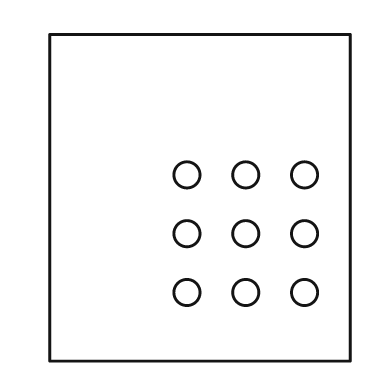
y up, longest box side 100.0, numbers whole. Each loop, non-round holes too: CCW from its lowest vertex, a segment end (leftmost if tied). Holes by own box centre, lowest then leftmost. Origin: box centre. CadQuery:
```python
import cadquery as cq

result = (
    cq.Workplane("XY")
    .moveTo(-46.0, -50.0)
    .lineTo(46.0, -50.0)
    .lineTo(46.0, 50.0)
    .lineTo(-46.0, 50.0)
    .close()
    .moveTo(-4.0, -29.0)
    .circle(4.0)
    .moveTo(14.0, -29.0)
    .circle(4.0)
    .moveTo(32.0, -29.0)
    .circle(4.0)
    .moveTo(-4.0, -11.0)
    .circle(4.0)
    .moveTo(14.0, -11.0)
    .circle(4.0)
    .moveTo(32.0, -11.0)
    .circle(4.0)
    .moveTo(-4.0, 7.0)
    .circle(4.0)
    .moveTo(14.0, 7.0)
    .circle(4.0)
    .moveTo(32.0, 7.0)
    .circle(4.0)
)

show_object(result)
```